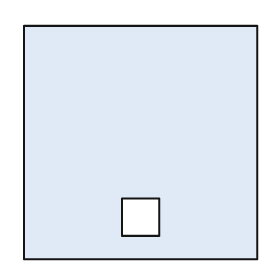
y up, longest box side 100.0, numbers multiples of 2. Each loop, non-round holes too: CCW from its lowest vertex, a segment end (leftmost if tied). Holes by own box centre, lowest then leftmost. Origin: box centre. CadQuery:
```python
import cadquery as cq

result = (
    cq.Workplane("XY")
    .moveTo(-50.0, -50.0)
    .lineTo(50.0, -50.0)
    .lineTo(50.0, 50.0)
    .lineTo(-50.0, 50.0)
    .close()
    .moveTo(-8.0, -40.0)
    .lineTo(8.0, -40.0)
    .lineTo(8.0, -24.0)
    .lineTo(-8.0, -24.0)
    .close()
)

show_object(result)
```